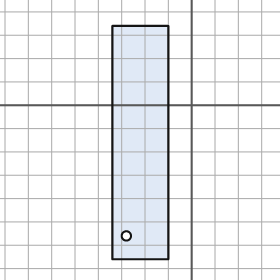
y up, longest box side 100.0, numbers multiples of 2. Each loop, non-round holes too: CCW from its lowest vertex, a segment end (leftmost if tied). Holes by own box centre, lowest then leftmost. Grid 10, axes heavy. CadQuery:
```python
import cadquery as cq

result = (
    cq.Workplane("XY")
    .moveTo(-34.0, -66.0)
    .lineTo(-10.0, -66.0)
    .lineTo(-10.0, 34.0)
    .lineTo(-34.0, 34.0)
    .close()
    .moveTo(-28.0, -56.0)
    .circle(2.0)
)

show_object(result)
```